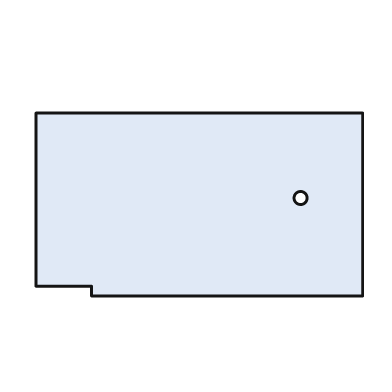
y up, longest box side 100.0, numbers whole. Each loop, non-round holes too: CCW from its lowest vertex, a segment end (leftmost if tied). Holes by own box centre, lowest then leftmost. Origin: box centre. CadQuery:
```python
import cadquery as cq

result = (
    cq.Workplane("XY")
    .moveTo(-33.0, -28.0)
    .lineTo(50.0, -28.0)
    .lineTo(50.0, 28.0)
    .lineTo(-50.0, 28.0)
    .lineTo(-50.0, -25.0)
    .lineTo(-33.0, -25.0)
    .close()
    .moveTo(31.0, 2.0)
    .circle(2.0)
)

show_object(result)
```